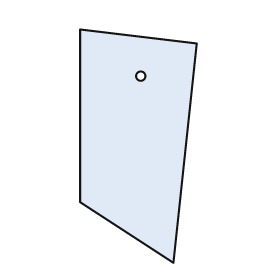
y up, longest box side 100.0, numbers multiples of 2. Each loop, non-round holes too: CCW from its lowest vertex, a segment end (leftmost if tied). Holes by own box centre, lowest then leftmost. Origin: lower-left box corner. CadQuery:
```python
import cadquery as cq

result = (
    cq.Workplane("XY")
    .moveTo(40.0, 0.0)
    .lineTo(50.0, 94.0)
    .lineTo(0.0, 100.0)
    .lineTo(0.0, 26.0)
    .close()
    .moveTo(26.0, 80.0)
    .circle(2.0)
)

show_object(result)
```